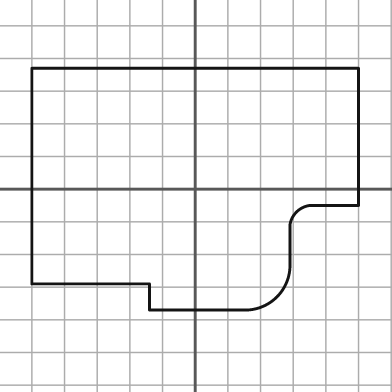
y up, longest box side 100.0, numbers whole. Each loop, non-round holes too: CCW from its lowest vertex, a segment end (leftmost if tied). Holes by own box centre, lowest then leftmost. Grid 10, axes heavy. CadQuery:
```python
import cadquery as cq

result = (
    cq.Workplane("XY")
    .moveTo(-14.0, -37.0)
    .lineTo(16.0, -37.0)
    .threePointArc((25.0, -33.0), (29.0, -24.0))
    .lineTo(29.0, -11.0)
    .threePointArc((31.0, -7.0), (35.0, -5.0))
    .lineTo(50.0, -5.0)
    .lineTo(50.0, 37.0)
    .lineTo(-50.0, 37.0)
    .lineTo(-50.0, -29.0)
    .lineTo(-14.0, -29.0)
    .close()
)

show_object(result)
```